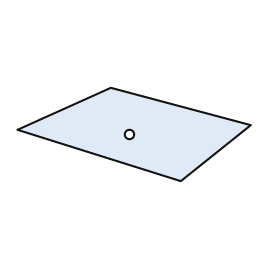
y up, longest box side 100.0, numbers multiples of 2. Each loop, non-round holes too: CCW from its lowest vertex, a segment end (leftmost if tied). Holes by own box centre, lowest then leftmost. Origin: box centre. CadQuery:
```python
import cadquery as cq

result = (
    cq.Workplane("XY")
    .moveTo(20.0, -20.0)
    .lineTo(50.0, 4.0)
    .lineTo(-10.0, 20.0)
    .lineTo(-50.0, 2.0)
    .close()
    .moveTo(-2.0, 0.0)
    .circle(2.0)
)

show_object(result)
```